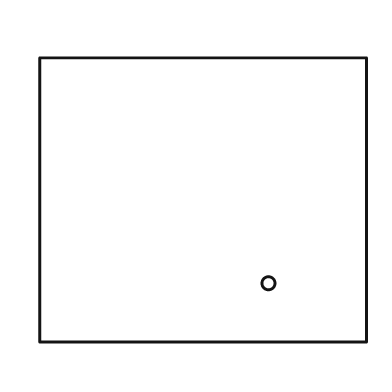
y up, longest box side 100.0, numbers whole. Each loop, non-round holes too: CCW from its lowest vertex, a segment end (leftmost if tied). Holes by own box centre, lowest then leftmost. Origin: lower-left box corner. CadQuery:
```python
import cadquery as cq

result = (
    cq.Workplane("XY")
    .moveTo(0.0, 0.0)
    .lineTo(100.0, 0.0)
    .lineTo(100.0, 87.0)
    .lineTo(0.0, 87.0)
    .close()
    .moveTo(70.0, 18.0)
    .circle(2.0)
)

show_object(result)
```